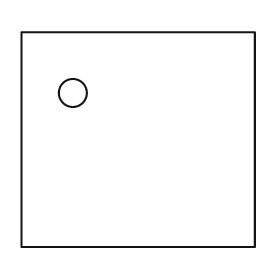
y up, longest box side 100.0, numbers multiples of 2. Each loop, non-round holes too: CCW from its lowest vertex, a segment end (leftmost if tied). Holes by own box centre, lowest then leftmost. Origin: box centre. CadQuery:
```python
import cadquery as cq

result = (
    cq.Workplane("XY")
    .moveTo(-50.0, -46.0)
    .lineTo(50.0, -46.0)
    .lineTo(50.0, 46.0)
    .lineTo(-50.0, 46.0)
    .close()
    .moveTo(-28.0, 20.0)
    .circle(6.0)
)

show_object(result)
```